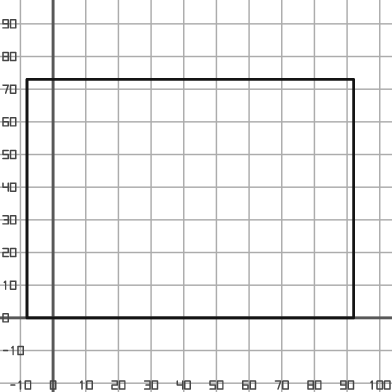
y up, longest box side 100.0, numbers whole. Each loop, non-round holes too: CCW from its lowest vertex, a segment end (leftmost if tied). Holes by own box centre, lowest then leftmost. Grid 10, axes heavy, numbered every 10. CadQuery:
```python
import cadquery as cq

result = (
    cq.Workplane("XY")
    .moveTo(-8.0, 0.0)
    .lineTo(92.0, 0.0)
    .lineTo(92.0, 73.0)
    .lineTo(-8.0, 73.0)
    .close()
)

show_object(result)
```